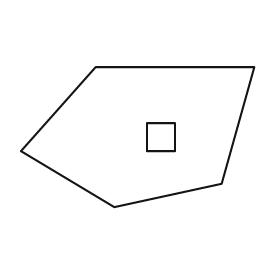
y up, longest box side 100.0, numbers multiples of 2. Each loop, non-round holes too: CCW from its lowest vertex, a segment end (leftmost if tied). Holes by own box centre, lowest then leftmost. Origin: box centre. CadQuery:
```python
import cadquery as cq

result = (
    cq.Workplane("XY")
    .moveTo(-10.0, -30.0)
    .lineTo(36.0, -20.0)
    .lineTo(50.0, 30.0)
    .lineTo(-18.0, 30.0)
    .lineTo(-50.0, -6.0)
    .close()
    .moveTo(4.0, -6.0)
    .lineTo(16.0, -6.0)
    .lineTo(16.0, 6.0)
    .lineTo(4.0, 6.0)
    .close()
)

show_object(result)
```